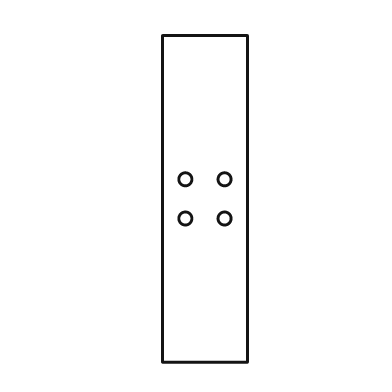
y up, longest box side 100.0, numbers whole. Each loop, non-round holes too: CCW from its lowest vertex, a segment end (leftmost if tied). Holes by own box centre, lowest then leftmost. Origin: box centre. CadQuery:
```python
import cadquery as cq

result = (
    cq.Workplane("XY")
    .moveTo(-13.0, -50.0)
    .lineTo(13.0, -50.0)
    .lineTo(13.0, 50.0)
    .lineTo(-13.0, 50.0)
    .close()
    .moveTo(-6.0, -6.0)
    .circle(2.0)
    .moveTo(6.0, -6.0)
    .circle(2.0)
    .moveTo(-6.0, 6.0)
    .circle(2.0)
    .moveTo(6.0, 6.0)
    .circle(2.0)
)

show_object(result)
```